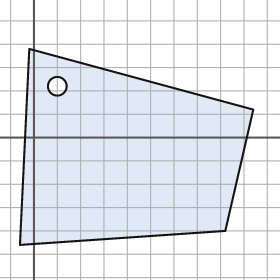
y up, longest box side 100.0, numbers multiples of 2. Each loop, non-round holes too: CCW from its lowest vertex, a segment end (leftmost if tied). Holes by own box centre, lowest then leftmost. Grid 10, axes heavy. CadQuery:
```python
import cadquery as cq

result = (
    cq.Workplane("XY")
    .moveTo(-6.0, -46.0)
    .lineTo(82.0, -40.0)
    .lineTo(94.0, 12.0)
    .lineTo(-2.0, 38.0)
    .close()
    .moveTo(10.0, 22.0)
    .circle(4.0)
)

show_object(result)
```